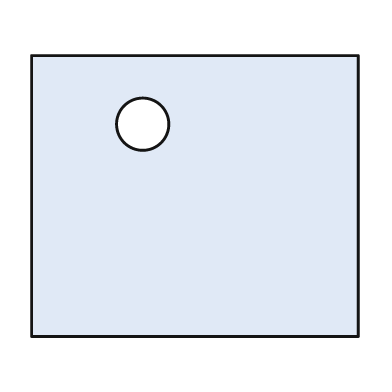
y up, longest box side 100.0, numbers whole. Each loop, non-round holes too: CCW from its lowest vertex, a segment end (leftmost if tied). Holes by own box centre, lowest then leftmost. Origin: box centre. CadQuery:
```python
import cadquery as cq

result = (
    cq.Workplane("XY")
    .moveTo(-50.0, -43.0)
    .lineTo(50.0, -43.0)
    .lineTo(50.0, 43.0)
    .lineTo(-50.0, 43.0)
    .close()
    .moveTo(-16.0, 22.0)
    .circle(8.0)
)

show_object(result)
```